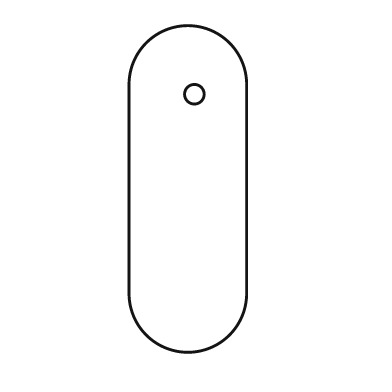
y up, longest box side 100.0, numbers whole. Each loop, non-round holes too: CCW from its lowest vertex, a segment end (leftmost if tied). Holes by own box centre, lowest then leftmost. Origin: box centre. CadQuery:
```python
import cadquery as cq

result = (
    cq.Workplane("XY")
    .moveTo(-18.0, -32.0)
    .threePointArc((0.0, -50.0), (18.0, -32.0))
    .lineTo(18.0, 32.0)
    .threePointArc((0.0, 50.0), (-18.0, 32.0))
    .close()
    .moveTo(2.0, 29.0)
    .circle(3.0)
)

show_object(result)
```